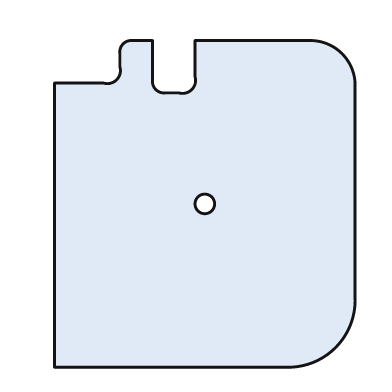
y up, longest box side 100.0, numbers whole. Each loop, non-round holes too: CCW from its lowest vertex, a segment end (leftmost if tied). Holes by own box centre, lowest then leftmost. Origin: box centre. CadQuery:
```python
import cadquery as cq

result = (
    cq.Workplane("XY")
    .moveTo(-46.0, -50.0)
    .lineTo(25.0, -50.0)
    .threePointArc((40.0, -44.0), (46.0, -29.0))
    .lineTo(46.0, 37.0)
    .threePointArc((42.0, 46.0), (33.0, 50.0))
    .lineTo(-3.0, 50.0)
    .lineTo(-3.0, 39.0)
    .threePointArc((-4.0, 35.0), (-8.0, 34.0))
    .lineTo(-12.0, 34.0)
    .threePointArc((-15.0, 35.0), (-16.0, 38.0))
    .lineTo(-16.0, 50.0)
    .lineTo(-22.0, 50.0)
    .threePointArc((-25.0, 49.0), (-26.0, 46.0))
    .lineTo(-26.0, 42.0)
    .threePointArc((-27.0, 38.0), (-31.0, 37.0))
    .lineTo(-46.0, 37.0)
    .close()
    .moveTo(0.0, 0.0)
    .circle(3.0)
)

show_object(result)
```